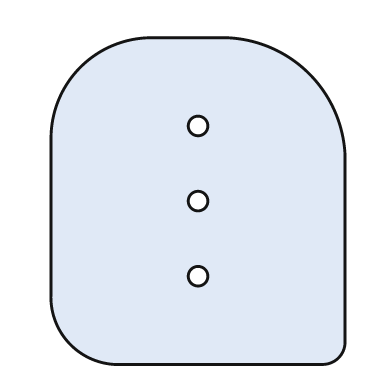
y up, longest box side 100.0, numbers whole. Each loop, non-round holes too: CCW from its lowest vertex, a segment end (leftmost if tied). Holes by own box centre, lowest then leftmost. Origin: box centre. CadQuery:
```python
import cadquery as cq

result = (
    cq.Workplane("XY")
    .moveTo(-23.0, -50.0)
    .lineTo(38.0, -50.0)
    .threePointArc((43.0, -48.0), (45.0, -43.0))
    .lineTo(45.0, 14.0)
    .threePointArc((34.0, 39.0), (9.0, 50.0))
    .lineTo(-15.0, 50.0)
    .threePointArc((-36.0, 41.0), (-45.0, 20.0))
    .lineTo(-45.0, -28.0)
    .threePointArc((-39.0, -44.0), (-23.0, -50.0))
    .close()
    .moveTo(0.0, -23.0)
    .circle(3.0)
    .moveTo(0.0, 0.0)
    .circle(3.0)
    .moveTo(0.0, 23.0)
    .circle(3.0)
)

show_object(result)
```